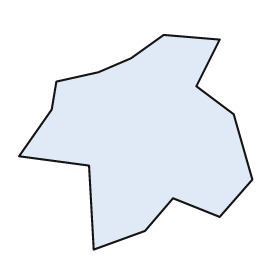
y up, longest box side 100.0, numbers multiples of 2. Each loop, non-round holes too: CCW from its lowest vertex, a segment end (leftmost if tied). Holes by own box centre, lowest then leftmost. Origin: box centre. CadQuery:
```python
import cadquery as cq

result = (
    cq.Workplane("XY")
    .moveTo(-18.0, -46.0)
    .lineTo(4.0, -38.0)
    .lineTo(16.0, -24.0)
    .lineTo(36.0, -32.0)
    .lineTo(50.0, -16.0)
    .lineTo(42.0, 12.0)
    .lineTo(26.0, 24.0)
    .lineTo(36.0, 44.0)
    .lineTo(12.0, 46.0)
    .lineTo(-2.0, 36.0)
    .lineTo(-16.0, 30.0)
    .lineTo(-34.0, 26.0)
    .lineTo(-36.0, 14.0)
    .lineTo(-50.0, -6.0)
    .lineTo(-20.0, -10.0)
    .close()
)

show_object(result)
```